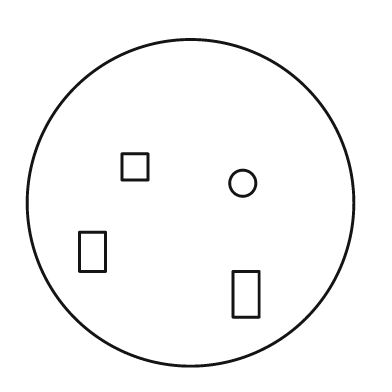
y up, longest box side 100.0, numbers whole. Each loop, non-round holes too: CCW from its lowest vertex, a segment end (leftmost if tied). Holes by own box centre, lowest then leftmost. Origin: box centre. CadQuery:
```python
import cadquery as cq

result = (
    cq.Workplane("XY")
    .moveTo(0.0, 0.0)
    .circle(50.0)
    .moveTo(13.0, -35.0)
    .lineTo(21.0, -35.0)
    .lineTo(21.0, -21.0)
    .lineTo(13.0, -21.0)
    .close()
    .moveTo(-34.0, -21.0)
    .lineTo(-26.0, -21.0)
    .lineTo(-26.0, -9.0)
    .lineTo(-34.0, -9.0)
    .close()
    .moveTo(16.0, 6.0)
    .circle(4.0)
    .moveTo(-21.0, 7.0)
    .lineTo(-13.0, 7.0)
    .lineTo(-13.0, 15.0)
    .lineTo(-21.0, 15.0)
    .close()
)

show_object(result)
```